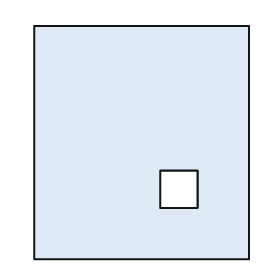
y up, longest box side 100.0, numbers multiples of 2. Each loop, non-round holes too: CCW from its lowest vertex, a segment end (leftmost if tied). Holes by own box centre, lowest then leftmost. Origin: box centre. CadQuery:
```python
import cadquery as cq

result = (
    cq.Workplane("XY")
    .moveTo(-46.0, -50.0)
    .lineTo(46.0, -50.0)
    .lineTo(46.0, 50.0)
    .lineTo(-46.0, 50.0)
    .close()
    .moveTo(8.0, -28.0)
    .lineTo(24.0, -28.0)
    .lineTo(24.0, -12.0)
    .lineTo(8.0, -12.0)
    .close()
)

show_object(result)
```